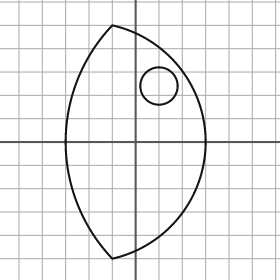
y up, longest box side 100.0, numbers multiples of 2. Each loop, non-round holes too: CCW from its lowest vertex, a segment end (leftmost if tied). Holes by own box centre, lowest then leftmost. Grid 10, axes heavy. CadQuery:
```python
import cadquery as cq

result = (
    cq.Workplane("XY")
    .moveTo(-10.0, -50.0)
    .threePointArc((30.0, 0.0), (-10.0, 50.0))
    .threePointArc((-30.0, 0.0), (-10.0, -50.0))
    .close()
    .moveTo(10.0, 24.0)
    .circle(8.0)
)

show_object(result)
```